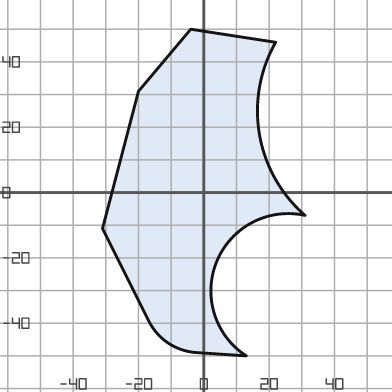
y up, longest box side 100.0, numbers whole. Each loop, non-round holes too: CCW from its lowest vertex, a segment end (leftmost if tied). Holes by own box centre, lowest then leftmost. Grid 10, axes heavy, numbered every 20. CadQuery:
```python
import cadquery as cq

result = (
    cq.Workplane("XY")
    .moveTo(13.0, -50.0)
    .threePointArc((4.0, -21.0), (31.0, -7.0))
    .threePointArc((17.0, 18.0), (22.0, 46.0))
    .lineTo(-4.0, 50.0)
    .lineTo(-20.0, 31.0)
    .lineTo(-31.0, -11.0)
    .lineTo(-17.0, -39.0)
    .threePointArc((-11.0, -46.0), (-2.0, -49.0))
    .close()
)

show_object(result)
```